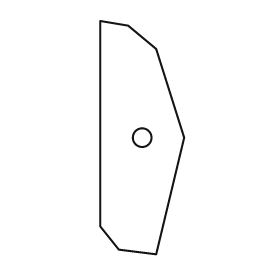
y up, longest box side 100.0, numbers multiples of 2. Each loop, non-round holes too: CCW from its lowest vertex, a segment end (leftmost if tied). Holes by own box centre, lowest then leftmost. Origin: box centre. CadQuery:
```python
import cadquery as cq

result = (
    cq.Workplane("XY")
    .moveTo(6.0, -50.0)
    .lineTo(18.0, 0.0)
    .lineTo(6.0, 38.0)
    .lineTo(-6.0, 48.0)
    .lineTo(-18.0, 50.0)
    .lineTo(-18.0, -38.0)
    .lineTo(-10.0, -48.0)
    .close()
    .moveTo(0.0, 0.0)
    .circle(4.0)
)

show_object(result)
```